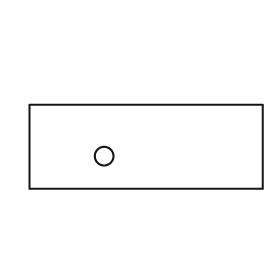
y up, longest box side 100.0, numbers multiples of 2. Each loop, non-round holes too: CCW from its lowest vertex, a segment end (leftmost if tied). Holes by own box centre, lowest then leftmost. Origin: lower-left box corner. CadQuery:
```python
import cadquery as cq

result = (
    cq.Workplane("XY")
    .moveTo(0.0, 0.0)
    .lineTo(100.0, 0.0)
    .lineTo(100.0, 36.0)
    .lineTo(0.0, 36.0)
    .close()
    .moveTo(32.0, 14.0)
    .circle(4.0)
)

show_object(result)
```